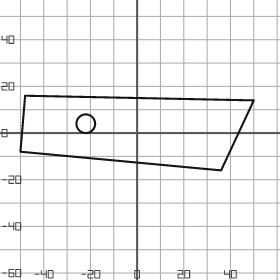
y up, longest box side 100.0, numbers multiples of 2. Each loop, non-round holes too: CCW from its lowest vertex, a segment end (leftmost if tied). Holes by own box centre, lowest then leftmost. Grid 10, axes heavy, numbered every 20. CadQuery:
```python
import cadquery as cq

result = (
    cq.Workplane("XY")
    .moveTo(36.0, -16.0)
    .lineTo(50.0, 14.0)
    .lineTo(-48.0, 16.0)
    .lineTo(-50.0, -8.0)
    .close()
    .moveTo(-22.0, 4.0)
    .circle(4.0)
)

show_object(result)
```